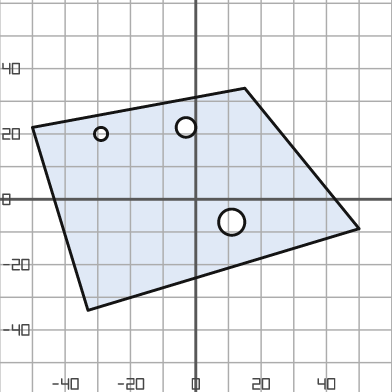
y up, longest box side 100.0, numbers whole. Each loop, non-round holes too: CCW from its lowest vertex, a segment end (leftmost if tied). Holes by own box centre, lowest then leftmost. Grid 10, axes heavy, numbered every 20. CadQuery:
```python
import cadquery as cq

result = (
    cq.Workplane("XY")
    .moveTo(-33.0, -34.0)
    .lineTo(50.0, -9.0)
    .lineTo(15.0, 34.0)
    .lineTo(-50.0, 22.0)
    .close()
    .moveTo(11.0, -7.0)
    .circle(4.0)
    .moveTo(-29.0, 20.0)
    .circle(2.0)
    .moveTo(-3.0, 22.0)
    .circle(3.0)
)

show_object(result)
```